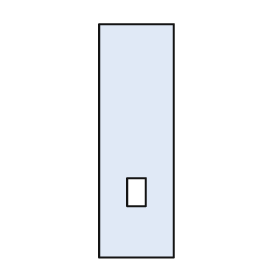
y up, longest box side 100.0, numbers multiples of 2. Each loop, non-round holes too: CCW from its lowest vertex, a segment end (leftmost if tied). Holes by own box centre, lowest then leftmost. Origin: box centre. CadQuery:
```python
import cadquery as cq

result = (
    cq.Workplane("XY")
    .moveTo(-16.0, -50.0)
    .lineTo(16.0, -50.0)
    .lineTo(16.0, 50.0)
    .lineTo(-16.0, 50.0)
    .close()
    .moveTo(-4.0, -28.0)
    .lineTo(4.0, -28.0)
    .lineTo(4.0, -16.0)
    .lineTo(-4.0, -16.0)
    .close()
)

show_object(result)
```